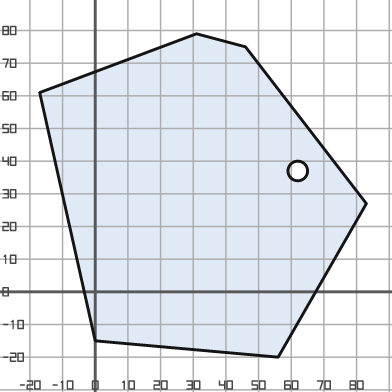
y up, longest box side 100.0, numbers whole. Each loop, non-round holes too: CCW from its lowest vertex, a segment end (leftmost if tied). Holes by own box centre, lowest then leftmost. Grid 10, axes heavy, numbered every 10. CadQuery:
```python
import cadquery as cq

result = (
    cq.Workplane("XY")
    .moveTo(56.0, -20.0)
    .lineTo(83.0, 27.0)
    .lineTo(46.0, 75.0)
    .lineTo(31.0, 79.0)
    .lineTo(-17.0, 61.0)
    .lineTo(0.0, -15.0)
    .close()
    .moveTo(62.0, 37.0)
    .circle(3.0)
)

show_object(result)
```